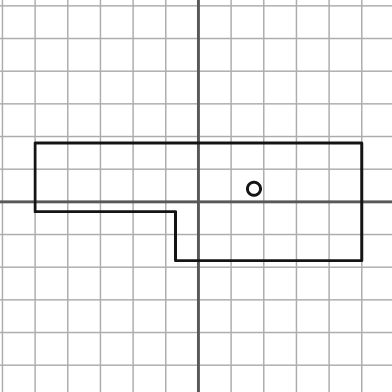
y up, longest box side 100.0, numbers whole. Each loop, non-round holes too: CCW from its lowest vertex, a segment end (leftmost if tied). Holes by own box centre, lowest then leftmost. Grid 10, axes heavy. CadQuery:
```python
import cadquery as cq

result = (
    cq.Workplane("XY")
    .moveTo(-7.0, -18.0)
    .lineTo(50.0, -18.0)
    .lineTo(50.0, 18.0)
    .lineTo(-50.0, 18.0)
    .lineTo(-50.0, -3.0)
    .lineTo(-7.0, -3.0)
    .close()
    .moveTo(17.0, 4.0)
    .circle(2.0)
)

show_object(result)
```